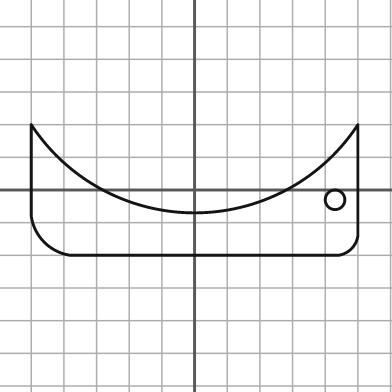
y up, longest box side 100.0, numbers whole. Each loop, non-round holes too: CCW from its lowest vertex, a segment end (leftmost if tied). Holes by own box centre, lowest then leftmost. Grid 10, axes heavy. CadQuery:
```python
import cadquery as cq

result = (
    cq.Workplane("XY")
    .moveTo(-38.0, -20.0)
    .lineTo(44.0, -20.0)
    .threePointArc((48.0, -18.0), (50.0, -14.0))
    .lineTo(50.0, 20.0)
    .threePointArc((0.0, -7.0), (-50.0, 20.0))
    .lineTo(-50.0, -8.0)
    .threePointArc((-46.0, -16.0), (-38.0, -20.0))
    .close()
    .moveTo(43.0, -3.0)
    .circle(3.0)
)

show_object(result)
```